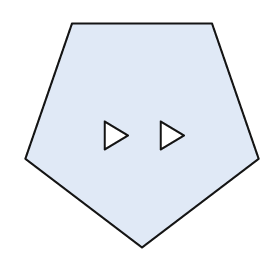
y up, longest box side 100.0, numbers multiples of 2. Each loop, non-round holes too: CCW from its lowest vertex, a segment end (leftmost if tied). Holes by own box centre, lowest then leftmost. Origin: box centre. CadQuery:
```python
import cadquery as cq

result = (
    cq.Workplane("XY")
    .moveTo(0.0, -48.0)
    .lineTo(50.0, -10.0)
    .lineTo(30.0, 48.0)
    .lineTo(-30.0, 48.0)
    .lineTo(-50.0, -10.0)
    .close()
    .moveTo(-16.0, -6.0)
    .lineTo(-6.0, 0.0)
    .lineTo(-16.0, 6.0)
    .close()
    .moveTo(8.0, -6.0)
    .lineTo(18.0, 0.0)
    .lineTo(8.0, 6.0)
    .close()
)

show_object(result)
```